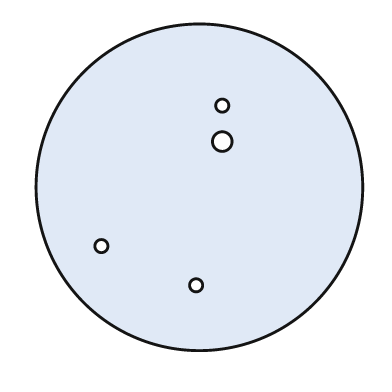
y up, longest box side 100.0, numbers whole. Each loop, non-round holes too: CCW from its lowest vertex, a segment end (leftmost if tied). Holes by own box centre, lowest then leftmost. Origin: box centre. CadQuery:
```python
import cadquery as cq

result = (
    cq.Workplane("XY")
    .moveTo(0.0, 0.0)
    .circle(50.0)
    .moveTo(-1.0, -30.0)
    .circle(2.0)
    .moveTo(-30.0, -18.0)
    .circle(2.0)
    .moveTo(7.0, 14.0)
    .circle(3.0)
    .moveTo(7.0, 25.0)
    .circle(2.0)
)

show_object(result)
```